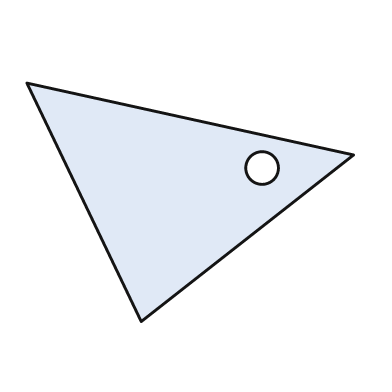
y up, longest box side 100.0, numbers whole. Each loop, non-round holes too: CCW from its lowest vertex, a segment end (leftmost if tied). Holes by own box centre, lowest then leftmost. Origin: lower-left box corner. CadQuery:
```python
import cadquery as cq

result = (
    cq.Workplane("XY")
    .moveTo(35.0, 0.0)
    .lineTo(100.0, 51.0)
    .lineTo(0.0, 73.0)
    .close()
    .moveTo(72.0, 47.0)
    .circle(5.0)
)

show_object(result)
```